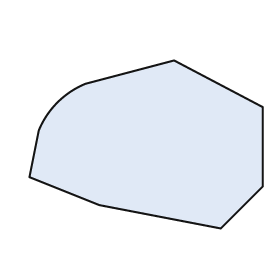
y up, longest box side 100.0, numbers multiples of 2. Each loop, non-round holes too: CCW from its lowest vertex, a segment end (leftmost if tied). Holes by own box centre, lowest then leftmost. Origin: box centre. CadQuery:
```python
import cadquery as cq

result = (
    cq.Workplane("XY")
    .moveTo(32.0, -36.0)
    .lineTo(50.0, -18.0)
    .lineTo(50.0, 16.0)
    .lineTo(12.0, 36.0)
    .lineTo(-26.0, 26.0)
    .threePointArc((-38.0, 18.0), (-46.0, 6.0))
    .lineTo(-50.0, -14.0)
    .lineTo(-20.0, -26.0)
    .close()
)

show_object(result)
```